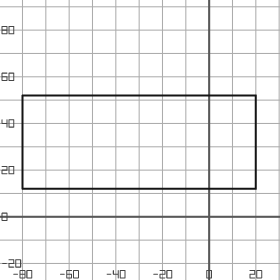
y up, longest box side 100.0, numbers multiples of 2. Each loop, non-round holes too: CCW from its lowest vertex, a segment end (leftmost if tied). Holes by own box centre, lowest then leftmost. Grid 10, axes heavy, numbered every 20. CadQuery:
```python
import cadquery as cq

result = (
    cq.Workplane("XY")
    .moveTo(-80.0, 12.0)
    .lineTo(20.0, 12.0)
    .lineTo(20.0, 52.0)
    .lineTo(-80.0, 52.0)
    .close()
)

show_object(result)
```